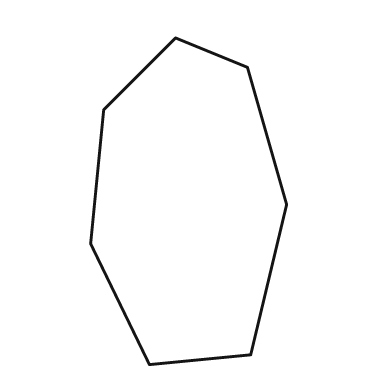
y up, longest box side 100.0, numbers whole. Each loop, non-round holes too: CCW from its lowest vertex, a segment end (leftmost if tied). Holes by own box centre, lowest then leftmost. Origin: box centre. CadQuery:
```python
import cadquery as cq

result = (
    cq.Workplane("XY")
    .moveTo(-12.0, -50.0)
    .lineTo(19.0, -47.0)
    .lineTo(30.0, -1.0)
    .lineTo(18.0, 41.0)
    .lineTo(-4.0, 50.0)
    .lineTo(-26.0, 28.0)
    .lineTo(-30.0, -13.0)
    .close()
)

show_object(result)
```